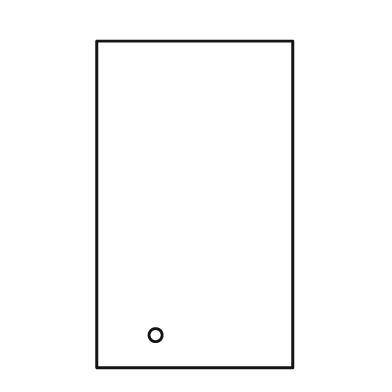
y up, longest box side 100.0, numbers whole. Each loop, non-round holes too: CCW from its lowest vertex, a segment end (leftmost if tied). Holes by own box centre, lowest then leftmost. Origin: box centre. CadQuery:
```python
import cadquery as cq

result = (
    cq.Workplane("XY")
    .moveTo(-30.0, -50.0)
    .lineTo(30.0, -50.0)
    .lineTo(30.0, 50.0)
    .lineTo(-30.0, 50.0)
    .close()
    .moveTo(-12.0, -40.0)
    .circle(2.0)
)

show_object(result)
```